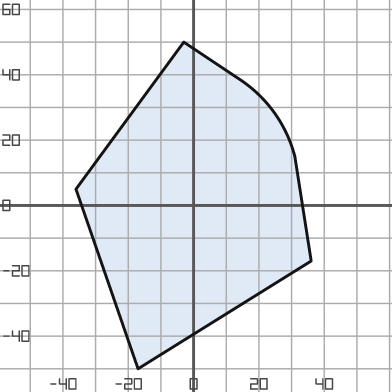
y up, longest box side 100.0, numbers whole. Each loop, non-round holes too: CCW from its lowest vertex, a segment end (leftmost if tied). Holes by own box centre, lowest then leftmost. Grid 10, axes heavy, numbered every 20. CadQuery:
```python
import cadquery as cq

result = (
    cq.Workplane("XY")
    .moveTo(-17.0, -50.0)
    .lineTo(36.0, -17.0)
    .lineTo(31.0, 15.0)
    .threePointArc((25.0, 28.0), (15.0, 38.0))
    .lineTo(-3.0, 50.0)
    .lineTo(-36.0, 5.0)
    .close()
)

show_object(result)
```